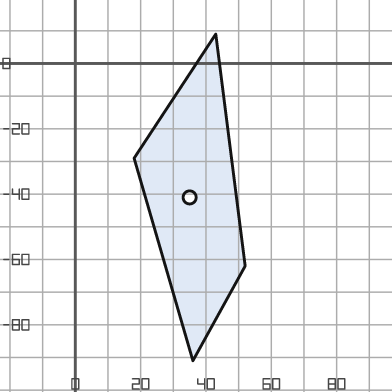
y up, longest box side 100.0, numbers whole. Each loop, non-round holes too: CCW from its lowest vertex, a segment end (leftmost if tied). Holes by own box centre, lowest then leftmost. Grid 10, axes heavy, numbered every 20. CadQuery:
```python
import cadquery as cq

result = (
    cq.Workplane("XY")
    .moveTo(36.0, -91.0)
    .lineTo(52.0, -62.0)
    .lineTo(43.0, 9.0)
    .lineTo(18.0, -29.0)
    .close()
    .moveTo(35.0, -41.0)
    .circle(2.0)
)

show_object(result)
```